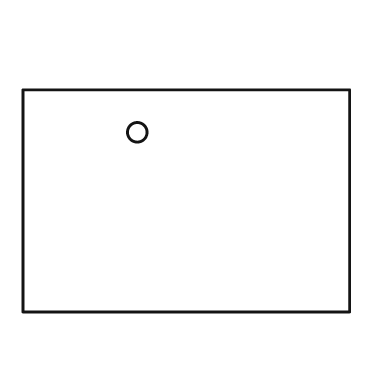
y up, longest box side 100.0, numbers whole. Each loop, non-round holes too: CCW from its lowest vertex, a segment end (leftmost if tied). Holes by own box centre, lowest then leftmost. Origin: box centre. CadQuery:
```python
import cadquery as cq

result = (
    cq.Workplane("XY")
    .moveTo(-50.0, -34.0)
    .lineTo(50.0, -34.0)
    .lineTo(50.0, 34.0)
    .lineTo(-50.0, 34.0)
    .close()
    .moveTo(-15.0, 21.0)
    .circle(3.0)
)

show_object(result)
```